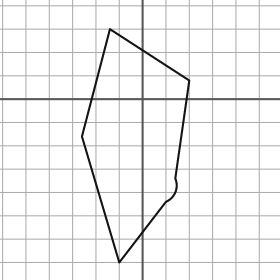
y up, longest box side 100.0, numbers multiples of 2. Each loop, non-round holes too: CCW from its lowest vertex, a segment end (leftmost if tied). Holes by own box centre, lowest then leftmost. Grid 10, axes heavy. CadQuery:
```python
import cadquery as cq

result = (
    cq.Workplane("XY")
    .moveTo(-10.0, -70.0)
    .lineTo(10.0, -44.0)
    .threePointArc((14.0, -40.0), (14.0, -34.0))
    .lineTo(20.0, 8.0)
    .lineTo(-14.0, 30.0)
    .lineTo(-26.0, -16.0)
    .close()
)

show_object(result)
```